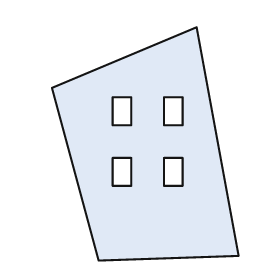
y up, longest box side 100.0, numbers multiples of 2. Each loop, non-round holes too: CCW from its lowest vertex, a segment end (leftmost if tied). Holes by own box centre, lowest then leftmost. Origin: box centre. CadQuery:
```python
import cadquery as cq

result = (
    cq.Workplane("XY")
    .moveTo(-20.0, -50.0)
    .lineTo(40.0, -48.0)
    .lineTo(22.0, 50.0)
    .lineTo(-40.0, 24.0)
    .close()
    .moveTo(-14.0, -18.0)
    .lineTo(-6.0, -18.0)
    .lineTo(-6.0, -6.0)
    .lineTo(-14.0, -6.0)
    .close()
    .moveTo(8.0, -18.0)
    .lineTo(16.0, -18.0)
    .lineTo(16.0, -6.0)
    .lineTo(8.0, -6.0)
    .close()
    .moveTo(-14.0, 8.0)
    .lineTo(-6.0, 8.0)
    .lineTo(-6.0, 20.0)
    .lineTo(-14.0, 20.0)
    .close()
    .moveTo(8.0, 8.0)
    .lineTo(16.0, 8.0)
    .lineTo(16.0, 20.0)
    .lineTo(8.0, 20.0)
    .close()
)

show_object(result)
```